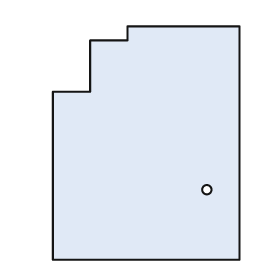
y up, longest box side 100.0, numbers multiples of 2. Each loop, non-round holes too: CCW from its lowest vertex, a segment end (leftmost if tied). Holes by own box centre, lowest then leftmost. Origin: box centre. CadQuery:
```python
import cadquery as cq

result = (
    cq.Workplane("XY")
    .moveTo(-40.0, -50.0)
    .lineTo(40.0, -50.0)
    .lineTo(40.0, 50.0)
    .lineTo(-8.0, 50.0)
    .lineTo(-8.0, 44.0)
    .lineTo(-24.0, 44.0)
    .lineTo(-24.0, 22.0)
    .lineTo(-40.0, 22.0)
    .close()
    .moveTo(26.0, -20.0)
    .circle(2.0)
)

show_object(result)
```